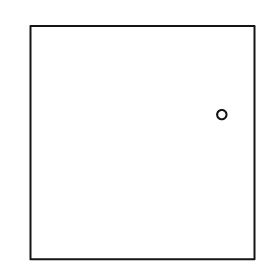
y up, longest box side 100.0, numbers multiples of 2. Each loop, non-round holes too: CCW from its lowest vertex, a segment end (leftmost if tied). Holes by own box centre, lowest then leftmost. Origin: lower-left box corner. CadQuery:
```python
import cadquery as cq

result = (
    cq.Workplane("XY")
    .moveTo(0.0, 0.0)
    .lineTo(96.0, 0.0)
    .lineTo(96.0, 100.0)
    .lineTo(0.0, 100.0)
    .close()
    .moveTo(82.0, 62.0)
    .circle(2.0)
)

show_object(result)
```